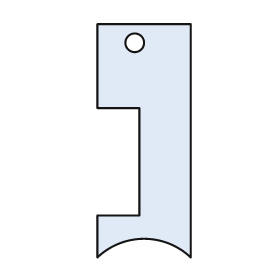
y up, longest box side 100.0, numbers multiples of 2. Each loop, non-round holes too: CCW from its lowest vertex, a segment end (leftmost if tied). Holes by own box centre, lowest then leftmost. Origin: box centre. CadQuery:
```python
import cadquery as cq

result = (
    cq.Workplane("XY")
    .moveTo(-20.0, -50.0)
    .threePointArc((0.0, -42.0), (20.0, -50.0))
    .lineTo(20.0, 50.0)
    .lineTo(-20.0, 50.0)
    .lineTo(-20.0, 14.0)
    .lineTo(-2.0, 14.0)
    .lineTo(-2.0, -32.0)
    .lineTo(-20.0, -32.0)
    .close()
    .moveTo(-4.0, 42.0)
    .circle(4.0)
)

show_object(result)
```